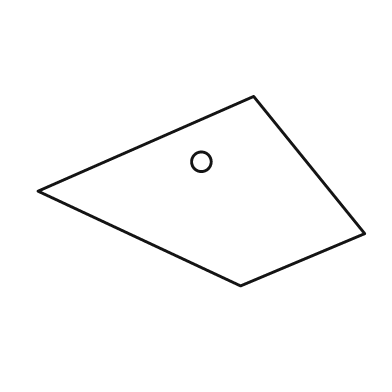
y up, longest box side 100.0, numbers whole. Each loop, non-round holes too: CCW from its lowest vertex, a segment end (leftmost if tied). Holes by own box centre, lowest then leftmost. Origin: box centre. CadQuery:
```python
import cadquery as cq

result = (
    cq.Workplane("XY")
    .moveTo(12.0, -29.0)
    .lineTo(50.0, -13.0)
    .lineTo(16.0, 29.0)
    .lineTo(-50.0, 0.0)
    .close()
    .moveTo(0.0, 9.0)
    .circle(3.0)
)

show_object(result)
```